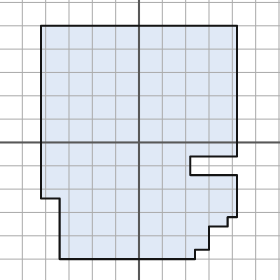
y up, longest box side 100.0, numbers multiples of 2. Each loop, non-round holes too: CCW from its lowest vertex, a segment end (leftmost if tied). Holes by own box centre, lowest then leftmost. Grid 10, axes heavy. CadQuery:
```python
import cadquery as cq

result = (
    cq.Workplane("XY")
    .moveTo(-34.0, -50.0)
    .lineTo(24.0, -50.0)
    .lineTo(24.0, -46.0)
    .lineTo(30.0, -46.0)
    .lineTo(30.0, -36.0)
    .lineTo(38.0, -36.0)
    .lineTo(38.0, -32.0)
    .lineTo(42.0, -32.0)
    .lineTo(42.0, -14.0)
    .lineTo(22.0, -14.0)
    .lineTo(22.0, -6.0)
    .lineTo(42.0, -6.0)
    .lineTo(42.0, 50.0)
    .lineTo(-42.0, 50.0)
    .lineTo(-42.0, -24.0)
    .lineTo(-34.0, -24.0)
    .close()
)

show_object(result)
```